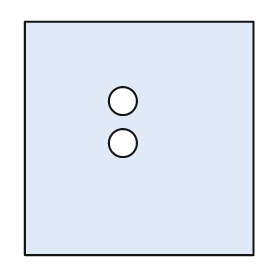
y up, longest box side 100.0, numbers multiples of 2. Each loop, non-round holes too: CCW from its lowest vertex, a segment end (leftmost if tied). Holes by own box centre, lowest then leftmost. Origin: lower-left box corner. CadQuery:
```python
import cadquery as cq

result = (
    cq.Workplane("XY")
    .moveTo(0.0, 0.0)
    .lineTo(98.0, 0.0)
    .lineTo(98.0, 100.0)
    .lineTo(0.0, 100.0)
    .close()
    .moveTo(42.0, 48.0)
    .circle(6.0)
    .moveTo(42.0, 66.0)
    .circle(6.0)
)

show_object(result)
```